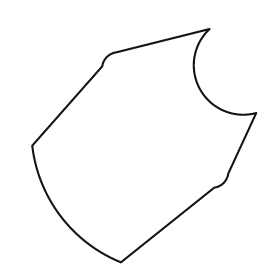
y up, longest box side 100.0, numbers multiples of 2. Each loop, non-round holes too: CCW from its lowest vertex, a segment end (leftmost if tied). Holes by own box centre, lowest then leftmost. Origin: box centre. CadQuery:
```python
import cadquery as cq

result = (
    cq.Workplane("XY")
    .moveTo(-10.0, -50.0)
    .lineTo(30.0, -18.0)
    .threePointArc((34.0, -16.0), (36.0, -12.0))
    .lineTo(48.0, 14.0)
    .threePointArc((24.0, 24.0), (28.0, 50.0))
    .lineTo(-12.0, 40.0)
    .threePointArc((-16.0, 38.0), (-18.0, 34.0))
    .lineTo(-48.0, 0.0)
    .threePointArc((-36.0, -30.0), (-10.0, -50.0))
    .close()
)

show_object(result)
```